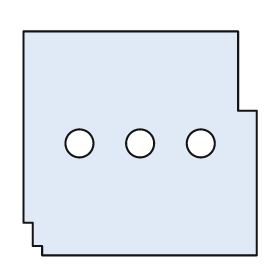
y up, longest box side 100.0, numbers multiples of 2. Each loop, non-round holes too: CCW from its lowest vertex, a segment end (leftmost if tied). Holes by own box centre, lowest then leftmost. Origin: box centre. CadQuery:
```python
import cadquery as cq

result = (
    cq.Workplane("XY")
    .moveTo(-42.0, -48.0)
    .lineTo(50.0, -48.0)
    .lineTo(50.0, 14.0)
    .lineTo(42.0, 14.0)
    .lineTo(42.0, 48.0)
    .lineTo(-50.0, 48.0)
    .lineTo(-50.0, -34.0)
    .lineTo(-46.0, -34.0)
    .lineTo(-46.0, -44.0)
    .lineTo(-42.0, -44.0)
    .close()
    .moveTo(-26.0, 0.0)
    .circle(6.0)
    .moveTo(0.0, 0.0)
    .circle(6.0)
    .moveTo(26.0, 0.0)
    .circle(6.0)
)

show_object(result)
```